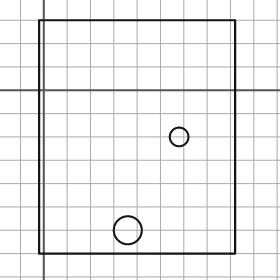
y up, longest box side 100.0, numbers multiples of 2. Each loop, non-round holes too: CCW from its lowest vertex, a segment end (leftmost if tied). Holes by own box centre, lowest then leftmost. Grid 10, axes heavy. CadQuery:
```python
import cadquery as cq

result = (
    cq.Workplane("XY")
    .moveTo(-2.0, -70.0)
    .lineTo(82.0, -70.0)
    .lineTo(82.0, 30.0)
    .lineTo(-2.0, 30.0)
    .close()
    .moveTo(36.0, -60.0)
    .circle(6.0)
    .moveTo(58.0, -20.0)
    .circle(4.0)
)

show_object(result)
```